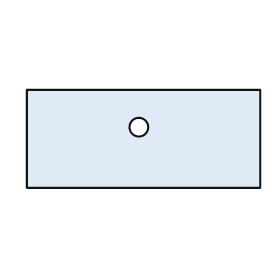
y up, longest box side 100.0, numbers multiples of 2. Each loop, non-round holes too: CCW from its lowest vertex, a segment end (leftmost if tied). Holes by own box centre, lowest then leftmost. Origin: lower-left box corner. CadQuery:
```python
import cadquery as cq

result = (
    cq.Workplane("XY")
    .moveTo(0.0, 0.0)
    .lineTo(100.0, 0.0)
    .lineTo(100.0, 42.0)
    .lineTo(0.0, 42.0)
    .close()
    .moveTo(48.0, 26.0)
    .circle(4.0)
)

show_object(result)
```